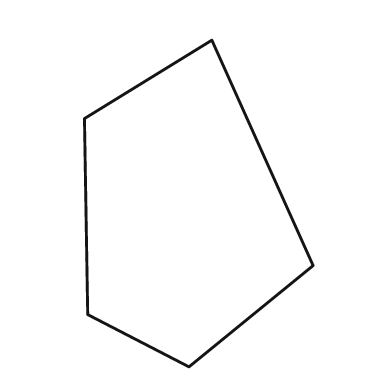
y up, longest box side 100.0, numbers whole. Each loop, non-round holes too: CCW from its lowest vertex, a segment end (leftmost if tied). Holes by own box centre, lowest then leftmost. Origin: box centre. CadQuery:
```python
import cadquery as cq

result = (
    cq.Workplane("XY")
    .moveTo(-3.0, -50.0)
    .lineTo(35.0, -19.0)
    .lineTo(4.0, 50.0)
    .lineTo(-35.0, 26.0)
    .lineTo(-34.0, -34.0)
    .close()
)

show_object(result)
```